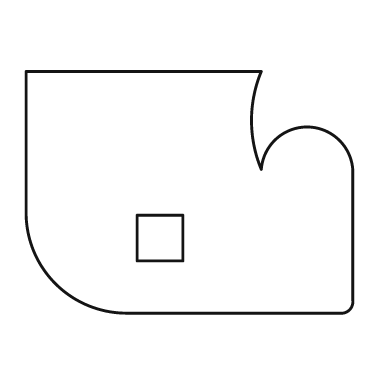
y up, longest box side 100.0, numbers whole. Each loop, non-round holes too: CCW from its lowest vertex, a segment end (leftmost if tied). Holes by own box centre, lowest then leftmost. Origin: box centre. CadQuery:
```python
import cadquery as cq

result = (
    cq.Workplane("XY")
    .moveTo(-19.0, -37.0)
    .lineTo(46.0, -37.0)
    .threePointArc((49.0, -36.0), (50.0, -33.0))
    .lineTo(50.0, 7.0)
    .threePointArc((36.0, 20.0), (22.0, 7.0))
    .threePointArc((19.0, 22.0), (22.0, 37.0))
    .lineTo(-50.0, 37.0)
    .lineTo(-50.0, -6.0)
    .threePointArc((-41.0, -28.0), (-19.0, -37.0))
    .close()
    .moveTo(-16.0, -21.0)
    .lineTo(-2.0, -21.0)
    .lineTo(-2.0, -7.0)
    .lineTo(-16.0, -7.0)
    .close()
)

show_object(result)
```